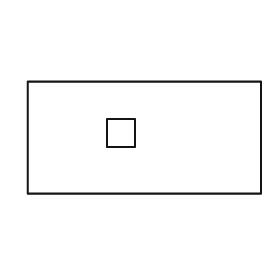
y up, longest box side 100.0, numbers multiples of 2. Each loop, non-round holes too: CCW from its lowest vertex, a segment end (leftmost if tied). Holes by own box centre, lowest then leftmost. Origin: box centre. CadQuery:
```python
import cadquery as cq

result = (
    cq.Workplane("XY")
    .moveTo(-50.0, -24.0)
    .lineTo(50.0, -24.0)
    .lineTo(50.0, 24.0)
    .lineTo(-50.0, 24.0)
    .close()
    .moveTo(-16.0, -4.0)
    .lineTo(-4.0, -4.0)
    .lineTo(-4.0, 8.0)
    .lineTo(-16.0, 8.0)
    .close()
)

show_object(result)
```